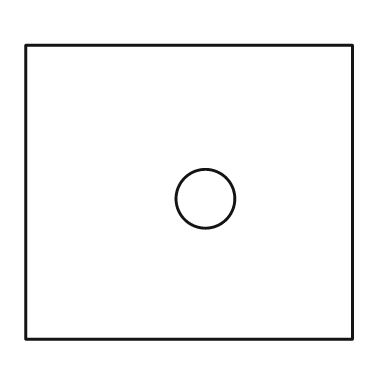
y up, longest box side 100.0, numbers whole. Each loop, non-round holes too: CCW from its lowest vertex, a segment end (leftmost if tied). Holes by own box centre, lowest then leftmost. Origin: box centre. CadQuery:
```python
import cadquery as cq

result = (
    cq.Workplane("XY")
    .moveTo(-50.0, -45.0)
    .lineTo(50.0, -45.0)
    .lineTo(50.0, 45.0)
    .lineTo(-50.0, 45.0)
    .close()
    .moveTo(5.0, -2.0)
    .circle(9.0)
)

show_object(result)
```